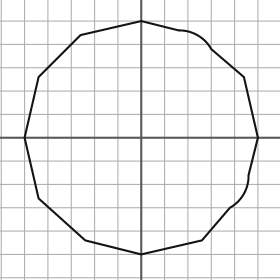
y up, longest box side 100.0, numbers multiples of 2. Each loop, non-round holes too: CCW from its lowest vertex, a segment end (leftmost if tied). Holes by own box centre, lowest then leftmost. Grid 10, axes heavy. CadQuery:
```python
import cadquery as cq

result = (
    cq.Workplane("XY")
    .moveTo(0.0, -50.0)
    .lineTo(26.0, -44.0)
    .lineTo(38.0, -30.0)
    .threePointArc((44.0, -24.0), (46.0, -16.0))
    .lineTo(50.0, 0.0)
    .lineTo(44.0, 26.0)
    .lineTo(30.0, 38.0)
    .threePointArc((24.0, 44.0), (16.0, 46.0))
    .lineTo(0.0, 50.0)
    .lineTo(-26.0, 44.0)
    .lineTo(-44.0, 26.0)
    .lineTo(-50.0, 0.0)
    .lineTo(-44.0, -26.0)
    .lineTo(-24.0, -44.0)
    .close()
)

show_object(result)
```